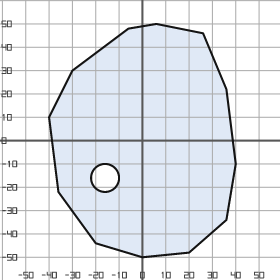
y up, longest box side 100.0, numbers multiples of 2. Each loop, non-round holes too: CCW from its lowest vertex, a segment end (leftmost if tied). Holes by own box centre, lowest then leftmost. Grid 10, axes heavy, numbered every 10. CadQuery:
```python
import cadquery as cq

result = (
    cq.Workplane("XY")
    .moveTo(0.0, -50.0)
    .lineTo(20.0, -48.0)
    .lineTo(36.0, -34.0)
    .lineTo(40.0, -10.0)
    .lineTo(36.0, 22.0)
    .lineTo(26.0, 46.0)
    .lineTo(6.0, 50.0)
    .lineTo(-6.0, 48.0)
    .lineTo(-30.0, 30.0)
    .lineTo(-40.0, 10.0)
    .lineTo(-36.0, -22.0)
    .lineTo(-20.0, -44.0)
    .close()
    .moveTo(-16.0, -16.0)
    .circle(6.0)
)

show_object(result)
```